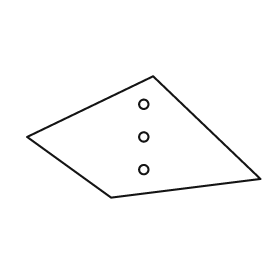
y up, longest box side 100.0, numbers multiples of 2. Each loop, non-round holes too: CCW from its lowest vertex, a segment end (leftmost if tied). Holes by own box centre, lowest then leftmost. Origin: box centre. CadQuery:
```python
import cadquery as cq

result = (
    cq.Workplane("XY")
    .moveTo(-14.0, -26.0)
    .lineTo(50.0, -18.0)
    .lineTo(4.0, 26.0)
    .lineTo(-50.0, 0.0)
    .close()
    .moveTo(0.0, -14.0)
    .circle(2.0)
    .moveTo(0.0, 0.0)
    .circle(2.0)
    .moveTo(0.0, 14.0)
    .circle(2.0)
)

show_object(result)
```